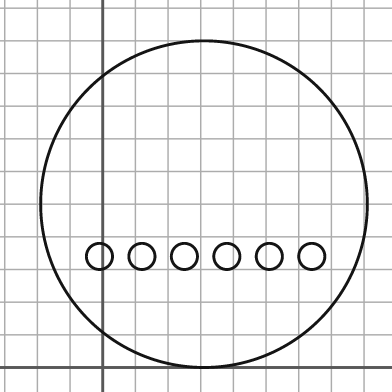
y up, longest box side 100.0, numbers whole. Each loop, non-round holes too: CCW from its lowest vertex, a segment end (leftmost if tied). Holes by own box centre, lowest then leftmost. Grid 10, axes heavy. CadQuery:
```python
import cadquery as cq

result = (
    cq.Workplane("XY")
    .moveTo(31.0, 50.0)
    .circle(50.0)
    .moveTo(-1.0, 34.0)
    .circle(4.0)
    .moveTo(12.0, 34.0)
    .circle(4.0)
    .moveTo(25.0, 34.0)
    .circle(4.0)
    .moveTo(38.0, 34.0)
    .circle(4.0)
    .moveTo(51.0, 34.0)
    .circle(4.0)
    .moveTo(64.0, 34.0)
    .circle(4.0)
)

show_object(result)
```